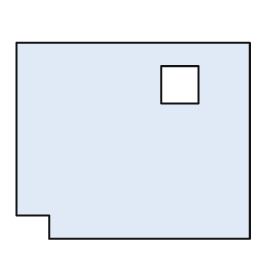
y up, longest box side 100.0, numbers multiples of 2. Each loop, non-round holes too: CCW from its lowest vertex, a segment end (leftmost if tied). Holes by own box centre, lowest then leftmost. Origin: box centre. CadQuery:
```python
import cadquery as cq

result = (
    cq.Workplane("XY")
    .moveTo(-36.0, -42.0)
    .lineTo(50.0, -42.0)
    .lineTo(50.0, 42.0)
    .lineTo(-50.0, 42.0)
    .lineTo(-50.0, -32.0)
    .lineTo(-36.0, -32.0)
    .close()
    .moveTo(12.0, 16.0)
    .lineTo(28.0, 16.0)
    .lineTo(28.0, 32.0)
    .lineTo(12.0, 32.0)
    .close()
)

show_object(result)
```